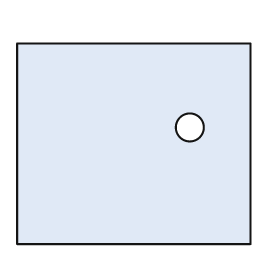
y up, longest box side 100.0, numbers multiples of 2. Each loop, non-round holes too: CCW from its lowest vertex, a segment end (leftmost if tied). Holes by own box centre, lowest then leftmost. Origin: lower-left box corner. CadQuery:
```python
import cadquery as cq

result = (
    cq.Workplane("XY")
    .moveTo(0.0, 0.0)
    .lineTo(100.0, 0.0)
    .lineTo(100.0, 86.0)
    .lineTo(0.0, 86.0)
    .close()
    .moveTo(74.0, 50.0)
    .circle(6.0)
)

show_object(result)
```